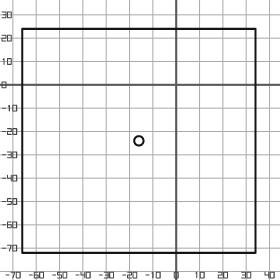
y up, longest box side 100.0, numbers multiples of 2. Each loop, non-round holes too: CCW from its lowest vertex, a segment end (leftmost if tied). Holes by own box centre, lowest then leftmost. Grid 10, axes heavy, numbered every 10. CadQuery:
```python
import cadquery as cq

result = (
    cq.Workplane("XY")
    .moveTo(-66.0, -72.0)
    .lineTo(34.0, -72.0)
    .lineTo(34.0, 24.0)
    .lineTo(-66.0, 24.0)
    .close()
    .moveTo(-16.0, -24.0)
    .circle(2.0)
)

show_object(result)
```